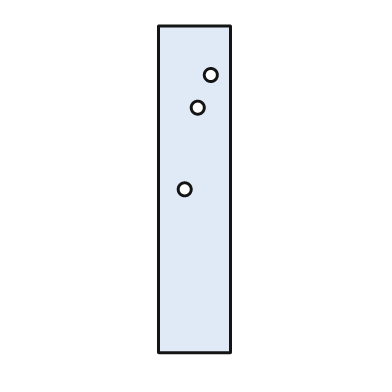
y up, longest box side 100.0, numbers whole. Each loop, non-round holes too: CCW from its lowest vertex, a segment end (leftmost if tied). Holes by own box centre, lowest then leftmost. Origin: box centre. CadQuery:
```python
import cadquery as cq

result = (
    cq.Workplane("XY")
    .moveTo(-11.0, -50.0)
    .lineTo(11.0, -50.0)
    .lineTo(11.0, 50.0)
    .lineTo(-11.0, 50.0)
    .close()
    .moveTo(-3.0, 0.0)
    .circle(2.0)
    .moveTo(1.0, 25.0)
    .circle(2.0)
    .moveTo(5.0, 35.0)
    .circle(2.0)
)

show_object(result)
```